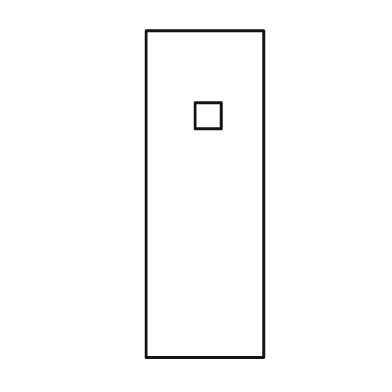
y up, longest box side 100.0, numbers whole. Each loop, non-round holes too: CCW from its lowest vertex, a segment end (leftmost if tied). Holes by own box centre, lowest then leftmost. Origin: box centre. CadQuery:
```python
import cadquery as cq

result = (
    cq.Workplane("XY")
    .moveTo(-18.0, -50.0)
    .lineTo(18.0, -50.0)
    .lineTo(18.0, 50.0)
    .lineTo(-18.0, 50.0)
    .close()
    .moveTo(-3.0, 20.0)
    .lineTo(5.0, 20.0)
    .lineTo(5.0, 28.0)
    .lineTo(-3.0, 28.0)
    .close()
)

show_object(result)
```